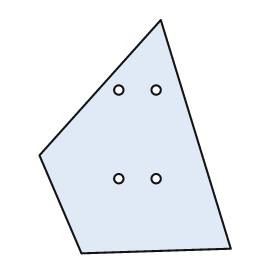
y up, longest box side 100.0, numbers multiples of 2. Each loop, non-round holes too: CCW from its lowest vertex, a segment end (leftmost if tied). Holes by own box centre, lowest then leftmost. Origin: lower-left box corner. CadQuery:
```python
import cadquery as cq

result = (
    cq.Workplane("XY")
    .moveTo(18.0, 0.0)
    .lineTo(82.0, 2.0)
    .lineTo(52.0, 100.0)
    .lineTo(0.0, 42.0)
    .close()
    .moveTo(34.0, 32.0)
    .circle(2.0)
    .moveTo(50.0, 32.0)
    .circle(2.0)
    .moveTo(34.0, 70.0)
    .circle(2.0)
    .moveTo(50.0, 70.0)
    .circle(2.0)
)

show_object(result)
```